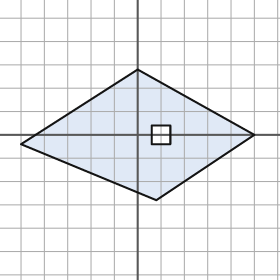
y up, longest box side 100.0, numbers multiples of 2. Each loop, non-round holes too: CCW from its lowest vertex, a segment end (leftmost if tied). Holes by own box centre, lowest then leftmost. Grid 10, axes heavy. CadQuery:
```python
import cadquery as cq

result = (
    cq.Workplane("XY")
    .moveTo(8.0, -28.0)
    .lineTo(50.0, 0.0)
    .lineTo(0.0, 28.0)
    .lineTo(-50.0, -4.0)
    .close()
    .moveTo(6.0, -4.0)
    .lineTo(14.0, -4.0)
    .lineTo(14.0, 4.0)
    .lineTo(6.0, 4.0)
    .close()
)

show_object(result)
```